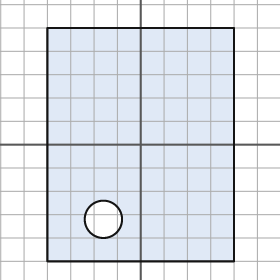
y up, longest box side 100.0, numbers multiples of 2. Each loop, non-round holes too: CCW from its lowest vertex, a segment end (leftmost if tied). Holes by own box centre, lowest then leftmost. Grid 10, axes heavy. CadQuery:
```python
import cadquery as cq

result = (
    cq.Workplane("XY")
    .moveTo(-40.0, -50.0)
    .lineTo(40.0, -50.0)
    .lineTo(40.0, 50.0)
    .lineTo(-40.0, 50.0)
    .close()
    .moveTo(-16.0, -32.0)
    .circle(8.0)
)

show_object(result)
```